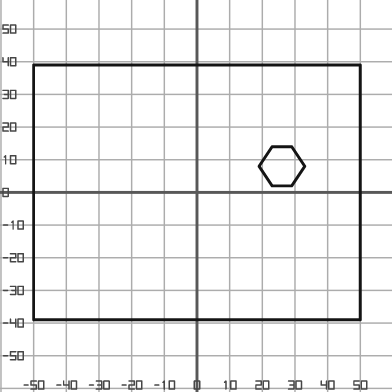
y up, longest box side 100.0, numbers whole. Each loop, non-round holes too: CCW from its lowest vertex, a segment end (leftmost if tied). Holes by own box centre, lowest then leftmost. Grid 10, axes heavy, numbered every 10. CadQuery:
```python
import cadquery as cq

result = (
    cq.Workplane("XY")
    .moveTo(-50.0, -39.0)
    .lineTo(50.0, -39.0)
    .lineTo(50.0, 39.0)
    .lineTo(-50.0, 39.0)
    .close()
    .moveTo(23.0, 2.0)
    .lineTo(29.0, 2.0)
    .lineTo(33.0, 8.0)
    .lineTo(29.0, 14.0)
    .lineTo(23.0, 14.0)
    .lineTo(19.0, 8.0)
    .close()
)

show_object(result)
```